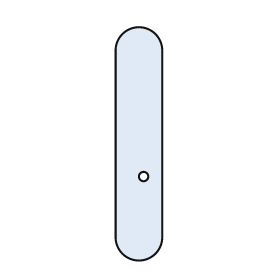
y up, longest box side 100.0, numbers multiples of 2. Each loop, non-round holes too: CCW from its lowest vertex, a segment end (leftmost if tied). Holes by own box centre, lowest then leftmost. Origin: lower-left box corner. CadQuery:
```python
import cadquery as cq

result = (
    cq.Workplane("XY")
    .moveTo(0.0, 10.0)
    .threePointArc((10.0, 0.0), (20.0, 10.0))
    .lineTo(20.0, 90.0)
    .threePointArc((10.0, 100.0), (0.0, 90.0))
    .close()
    .moveTo(12.0, 36.0)
    .circle(2.0)
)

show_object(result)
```